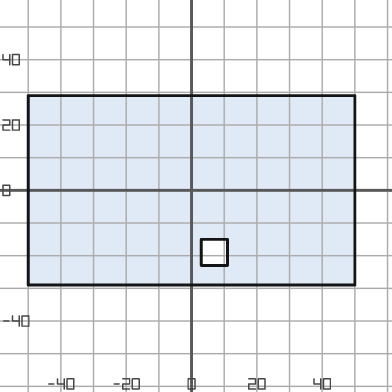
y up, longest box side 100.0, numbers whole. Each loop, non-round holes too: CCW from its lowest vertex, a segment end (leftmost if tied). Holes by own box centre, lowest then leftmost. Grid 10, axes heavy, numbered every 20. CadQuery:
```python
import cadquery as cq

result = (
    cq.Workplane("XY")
    .moveTo(-50.0, -29.0)
    .lineTo(50.0, -29.0)
    .lineTo(50.0, 29.0)
    .lineTo(-50.0, 29.0)
    .close()
    .moveTo(3.0, -23.0)
    .lineTo(11.0, -23.0)
    .lineTo(11.0, -15.0)
    .lineTo(3.0, -15.0)
    .close()
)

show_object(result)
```